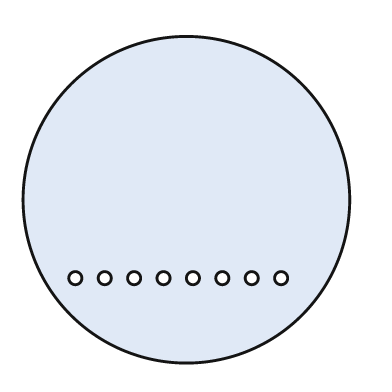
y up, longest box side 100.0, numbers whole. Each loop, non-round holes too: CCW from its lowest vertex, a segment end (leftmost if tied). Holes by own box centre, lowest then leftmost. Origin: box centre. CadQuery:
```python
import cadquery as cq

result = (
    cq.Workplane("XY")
    .moveTo(0.0, 0.0)
    .circle(50.0)
    .moveTo(-34.0, -24.0)
    .circle(2.0)
    .moveTo(-25.0, -24.0)
    .circle(2.0)
    .moveTo(-16.0, -24.0)
    .circle(2.0)
    .moveTo(-7.0, -24.0)
    .circle(2.0)
    .moveTo(2.0, -24.0)
    .circle(2.0)
    .moveTo(11.0, -24.0)
    .circle(2.0)
    .moveTo(20.0, -24.0)
    .circle(2.0)
    .moveTo(29.0, -24.0)
    .circle(2.0)
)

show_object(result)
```